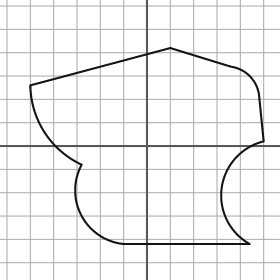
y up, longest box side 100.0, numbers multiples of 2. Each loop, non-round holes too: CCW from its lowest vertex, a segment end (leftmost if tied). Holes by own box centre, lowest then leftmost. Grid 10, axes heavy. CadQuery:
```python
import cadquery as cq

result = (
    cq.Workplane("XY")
    .moveTo(-10.0, -42.0)
    .lineTo(44.0, -42.0)
    .threePointArc((32.0, -18.0), (50.0, 2.0))
    .lineTo(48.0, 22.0)
    .threePointArc((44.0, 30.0), (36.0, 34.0))
    .lineTo(10.0, 42.0)
    .lineTo(-50.0, 26.0)
    .threePointArc((-44.0, 6.0), (-28.0, -8.0))
    .threePointArc((-28.0, -30.0), (-10.0, -42.0))
    .close()
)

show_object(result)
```